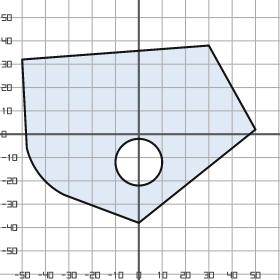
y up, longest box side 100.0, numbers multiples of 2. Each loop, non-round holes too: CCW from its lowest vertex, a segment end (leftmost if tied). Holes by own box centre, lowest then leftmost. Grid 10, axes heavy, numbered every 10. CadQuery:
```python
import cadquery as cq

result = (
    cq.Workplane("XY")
    .moveTo(0.0, -38.0)
    .lineTo(50.0, 2.0)
    .lineTo(30.0, 38.0)
    .lineTo(-50.0, 32.0)
    .lineTo(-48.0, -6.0)
    .threePointArc((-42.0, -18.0), (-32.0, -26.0))
    .close()
    .moveTo(0.0, -12.0)
    .circle(10.0)
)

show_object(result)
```